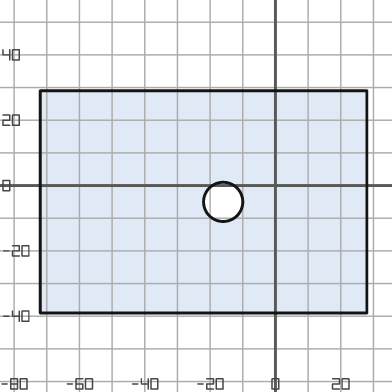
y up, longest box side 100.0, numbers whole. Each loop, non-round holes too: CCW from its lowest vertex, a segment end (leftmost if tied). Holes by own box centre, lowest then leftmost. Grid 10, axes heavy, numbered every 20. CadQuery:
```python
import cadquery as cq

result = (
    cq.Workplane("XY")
    .moveTo(-72.0, -39.0)
    .lineTo(28.0, -39.0)
    .lineTo(28.0, 29.0)
    .lineTo(-72.0, 29.0)
    .close()
    .moveTo(-16.0, -5.0)
    .circle(6.0)
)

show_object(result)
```